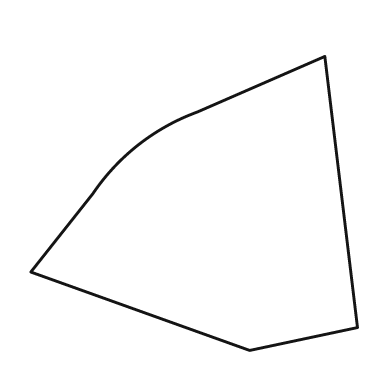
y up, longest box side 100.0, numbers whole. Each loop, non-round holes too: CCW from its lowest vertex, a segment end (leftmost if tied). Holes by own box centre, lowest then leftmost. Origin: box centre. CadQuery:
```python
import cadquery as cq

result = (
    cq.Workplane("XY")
    .moveTo(17.0, -45.0)
    .lineTo(50.0, -38.0)
    .lineTo(40.0, 45.0)
    .lineTo(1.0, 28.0)
    .threePointArc((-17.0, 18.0), (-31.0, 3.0))
    .lineTo(-50.0, -21.0)
    .close()
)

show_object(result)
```